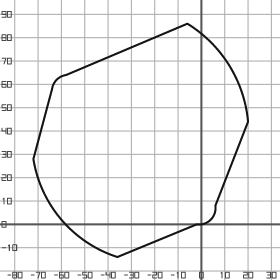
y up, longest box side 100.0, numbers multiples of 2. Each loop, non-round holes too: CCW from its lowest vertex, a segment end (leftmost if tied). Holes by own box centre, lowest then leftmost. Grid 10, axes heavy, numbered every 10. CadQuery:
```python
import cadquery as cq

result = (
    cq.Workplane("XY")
    .moveTo(-36.0, -14.0)
    .lineTo(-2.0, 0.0)
    .threePointArc((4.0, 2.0), (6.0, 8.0))
    .lineTo(20.0, 44.0)
    .threePointArc((12.0, 68.0), (-6.0, 86.0))
    .lineTo(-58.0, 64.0)
    .threePointArc((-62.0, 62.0), (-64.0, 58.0))
    .lineTo(-72.0, 28.0)
    .threePointArc((-60.0, 2.0), (-36.0, -14.0))
    .close()
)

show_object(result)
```